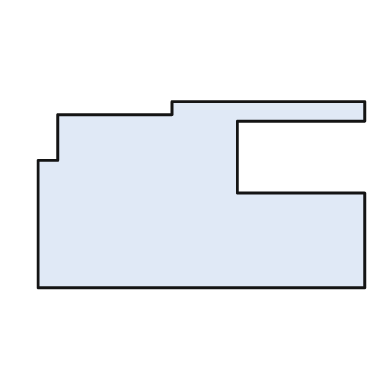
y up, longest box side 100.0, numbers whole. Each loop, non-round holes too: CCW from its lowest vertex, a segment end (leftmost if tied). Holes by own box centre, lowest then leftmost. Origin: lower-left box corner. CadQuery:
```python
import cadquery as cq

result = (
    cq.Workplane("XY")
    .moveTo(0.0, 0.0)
    .lineTo(100.0, 0.0)
    .lineTo(100.0, 29.0)
    .lineTo(61.0, 29.0)
    .lineTo(61.0, 51.0)
    .lineTo(100.0, 51.0)
    .lineTo(100.0, 57.0)
    .lineTo(41.0, 57.0)
    .lineTo(41.0, 53.0)
    .lineTo(6.0, 53.0)
    .lineTo(6.0, 39.0)
    .lineTo(0.0, 39.0)
    .close()
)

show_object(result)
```